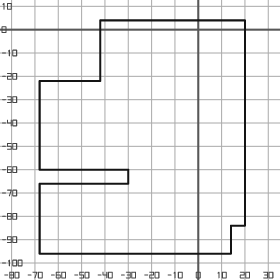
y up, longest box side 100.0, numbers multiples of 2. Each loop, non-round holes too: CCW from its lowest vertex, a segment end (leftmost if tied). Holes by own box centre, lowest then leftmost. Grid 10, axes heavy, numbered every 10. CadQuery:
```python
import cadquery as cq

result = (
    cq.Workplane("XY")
    .moveTo(-68.0, -96.0)
    .lineTo(14.0, -96.0)
    .lineTo(14.0, -84.0)
    .lineTo(20.0, -84.0)
    .lineTo(20.0, 4.0)
    .lineTo(-42.0, 4.0)
    .lineTo(-42.0, -22.0)
    .lineTo(-68.0, -22.0)
    .lineTo(-68.0, -60.0)
    .lineTo(-30.0, -60.0)
    .lineTo(-30.0, -66.0)
    .lineTo(-68.0, -66.0)
    .close()
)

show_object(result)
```